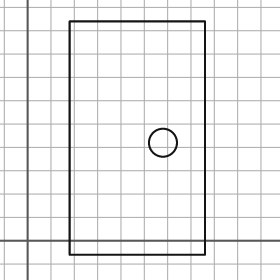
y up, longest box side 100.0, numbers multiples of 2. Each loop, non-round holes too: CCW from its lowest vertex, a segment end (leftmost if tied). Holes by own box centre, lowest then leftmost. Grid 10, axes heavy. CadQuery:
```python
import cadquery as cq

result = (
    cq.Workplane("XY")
    .moveTo(18.0, -6.0)
    .lineTo(76.0, -6.0)
    .lineTo(76.0, 94.0)
    .lineTo(18.0, 94.0)
    .close()
    .moveTo(58.0, 42.0)
    .circle(6.0)
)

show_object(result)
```